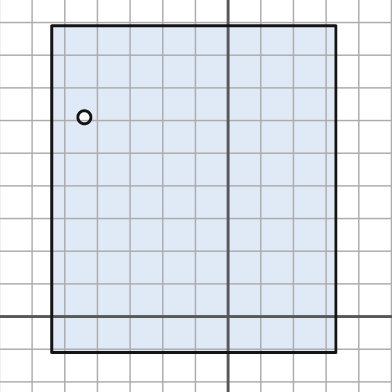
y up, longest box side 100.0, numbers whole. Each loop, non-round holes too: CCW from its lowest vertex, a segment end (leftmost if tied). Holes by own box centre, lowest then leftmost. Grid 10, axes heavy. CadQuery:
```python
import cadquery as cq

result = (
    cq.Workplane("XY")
    .moveTo(-54.0, -11.0)
    .lineTo(33.0, -11.0)
    .lineTo(33.0, 89.0)
    .lineTo(-54.0, 89.0)
    .close()
    .moveTo(-44.0, 61.0)
    .circle(2.0)
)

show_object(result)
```